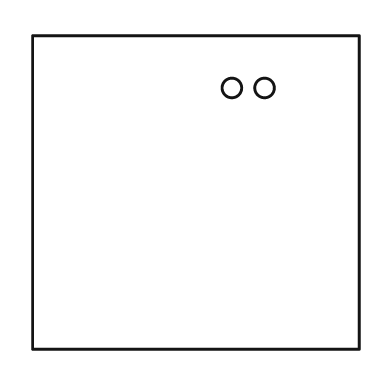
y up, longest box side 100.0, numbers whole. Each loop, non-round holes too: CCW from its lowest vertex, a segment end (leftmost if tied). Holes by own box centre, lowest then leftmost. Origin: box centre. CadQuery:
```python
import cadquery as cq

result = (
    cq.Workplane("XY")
    .moveTo(-50.0, -48.0)
    .lineTo(50.0, -48.0)
    .lineTo(50.0, 48.0)
    .lineTo(-50.0, 48.0)
    .close()
    .moveTo(11.0, 32.0)
    .circle(3.0)
    .moveTo(21.0, 32.0)
    .circle(3.0)
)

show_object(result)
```